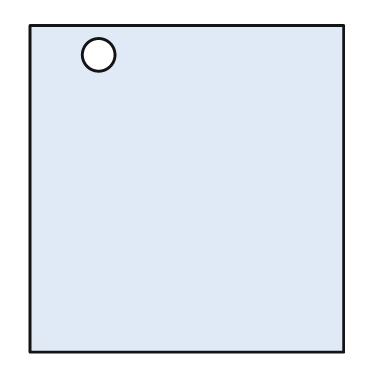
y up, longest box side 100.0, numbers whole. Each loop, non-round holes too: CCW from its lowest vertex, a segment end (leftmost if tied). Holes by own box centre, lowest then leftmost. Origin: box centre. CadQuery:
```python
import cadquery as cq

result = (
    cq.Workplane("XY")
    .moveTo(-48.0, -50.0)
    .lineTo(48.0, -50.0)
    .lineTo(48.0, 50.0)
    .lineTo(-48.0, 50.0)
    .close()
    .moveTo(-27.0, 41.0)
    .circle(5.0)
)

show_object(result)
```